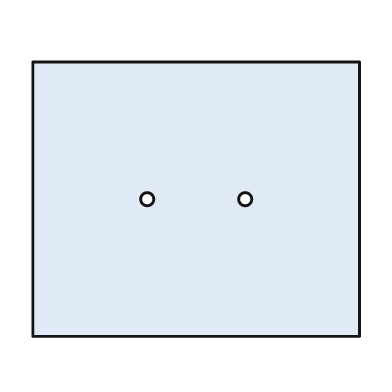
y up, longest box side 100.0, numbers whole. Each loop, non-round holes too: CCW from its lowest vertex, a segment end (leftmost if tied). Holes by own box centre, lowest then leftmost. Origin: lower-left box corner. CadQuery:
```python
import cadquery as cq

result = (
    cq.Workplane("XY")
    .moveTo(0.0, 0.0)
    .lineTo(100.0, 0.0)
    .lineTo(100.0, 84.0)
    .lineTo(0.0, 84.0)
    .close()
    .moveTo(35.0, 42.0)
    .circle(2.0)
    .moveTo(65.0, 42.0)
    .circle(2.0)
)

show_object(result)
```